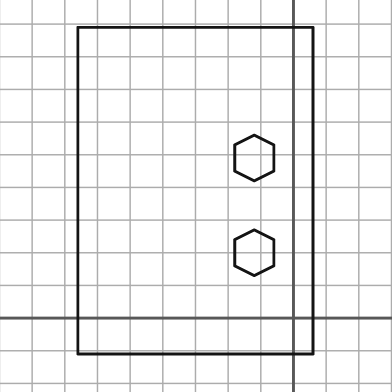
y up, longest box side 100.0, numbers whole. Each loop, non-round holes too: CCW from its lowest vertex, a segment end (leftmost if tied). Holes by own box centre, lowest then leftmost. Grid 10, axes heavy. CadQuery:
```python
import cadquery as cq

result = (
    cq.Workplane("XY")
    .moveTo(-66.0, -11.0)
    .lineTo(6.0, -11.0)
    .lineTo(6.0, 89.0)
    .lineTo(-66.0, 89.0)
    .close()
    .moveTo(-12.0, 13.0)
    .lineTo(-6.0, 16.0)
    .lineTo(-6.0, 24.0)
    .lineTo(-12.0, 27.0)
    .lineTo(-18.0, 24.0)
    .lineTo(-18.0, 16.0)
    .close()
    .moveTo(-12.0, 42.0)
    .lineTo(-6.0, 45.0)
    .lineTo(-6.0, 53.0)
    .lineTo(-12.0, 56.0)
    .lineTo(-18.0, 53.0)
    .lineTo(-18.0, 45.0)
    .close()
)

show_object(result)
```